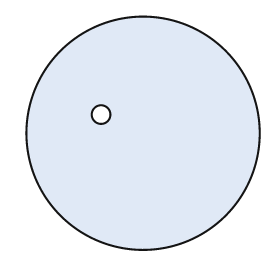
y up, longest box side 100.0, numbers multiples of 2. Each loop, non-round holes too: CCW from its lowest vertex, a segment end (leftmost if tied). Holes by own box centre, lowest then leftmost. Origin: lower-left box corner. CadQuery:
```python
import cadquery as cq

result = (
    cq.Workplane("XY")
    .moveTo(50.0, 50.0)
    .circle(50.0)
    .moveTo(32.0, 58.0)
    .circle(4.0)
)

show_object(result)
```